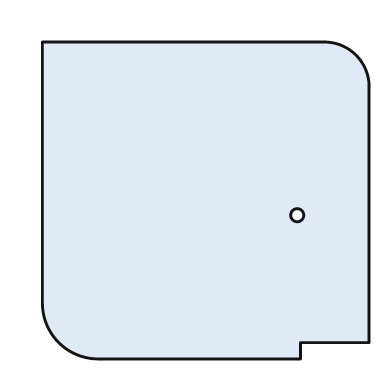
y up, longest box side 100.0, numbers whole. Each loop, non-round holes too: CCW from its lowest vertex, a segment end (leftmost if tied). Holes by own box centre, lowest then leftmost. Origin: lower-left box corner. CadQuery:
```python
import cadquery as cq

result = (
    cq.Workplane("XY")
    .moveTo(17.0, 0.0)
    .lineTo(79.0, 0.0)
    .lineTo(79.0, 5.0)
    .lineTo(100.0, 5.0)
    .lineTo(100.0, 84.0)
    .threePointArc((96.0, 93.0), (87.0, 97.0))
    .lineTo(0.0, 97.0)
    .lineTo(0.0, 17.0)
    .threePointArc((5.0, 5.0), (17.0, 0.0))
    .close()
    .moveTo(78.0, 44.0)
    .circle(2.0)
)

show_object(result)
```